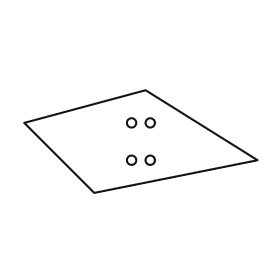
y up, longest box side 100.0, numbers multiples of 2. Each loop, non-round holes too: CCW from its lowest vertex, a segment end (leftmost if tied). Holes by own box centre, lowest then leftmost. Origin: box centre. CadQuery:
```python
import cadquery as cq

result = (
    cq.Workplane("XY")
    .moveTo(-20.0, -22.0)
    .lineTo(50.0, -8.0)
    .lineTo(2.0, 22.0)
    .lineTo(-50.0, 8.0)
    .close()
    .moveTo(-4.0, -8.0)
    .circle(2.0)
    .moveTo(4.0, -8.0)
    .circle(2.0)
    .moveTo(-4.0, 8.0)
    .circle(2.0)
    .moveTo(4.0, 8.0)
    .circle(2.0)
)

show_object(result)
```